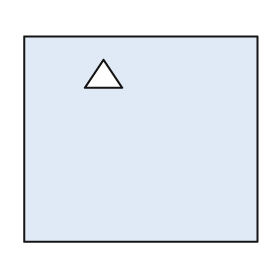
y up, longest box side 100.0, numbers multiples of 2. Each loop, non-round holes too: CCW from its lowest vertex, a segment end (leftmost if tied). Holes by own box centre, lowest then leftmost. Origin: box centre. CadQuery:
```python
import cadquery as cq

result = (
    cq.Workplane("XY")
    .moveTo(-50.0, -44.0)
    .lineTo(50.0, -44.0)
    .lineTo(50.0, 44.0)
    .lineTo(-50.0, 44.0)
    .close()
    .moveTo(-24.0, 22.0)
    .lineTo(-8.0, 22.0)
    .lineTo(-16.0, 34.0)
    .close()
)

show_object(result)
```